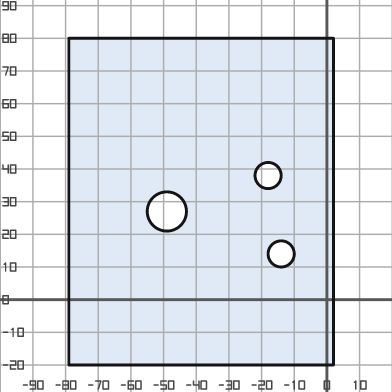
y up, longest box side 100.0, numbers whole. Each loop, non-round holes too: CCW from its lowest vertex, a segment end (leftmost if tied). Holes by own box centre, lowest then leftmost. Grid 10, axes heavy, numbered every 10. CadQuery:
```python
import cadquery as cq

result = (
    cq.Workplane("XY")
    .moveTo(-79.0, -20.0)
    .lineTo(2.0, -20.0)
    .lineTo(2.0, 80.0)
    .lineTo(-79.0, 80.0)
    .close()
    .moveTo(-14.0, 14.0)
    .circle(4.0)
    .moveTo(-49.0, 27.0)
    .circle(6.0)
    .moveTo(-18.0, 38.0)
    .circle(4.0)
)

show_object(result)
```